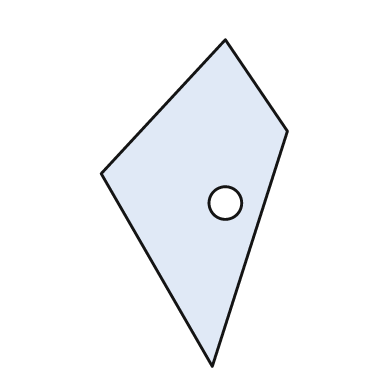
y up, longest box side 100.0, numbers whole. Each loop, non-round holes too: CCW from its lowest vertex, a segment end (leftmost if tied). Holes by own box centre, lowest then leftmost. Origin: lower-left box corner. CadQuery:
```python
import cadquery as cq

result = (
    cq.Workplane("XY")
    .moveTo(34.0, 0.0)
    .lineTo(57.0, 72.0)
    .lineTo(38.0, 100.0)
    .lineTo(0.0, 59.0)
    .close()
    .moveTo(38.0, 50.0)
    .circle(5.0)
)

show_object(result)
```